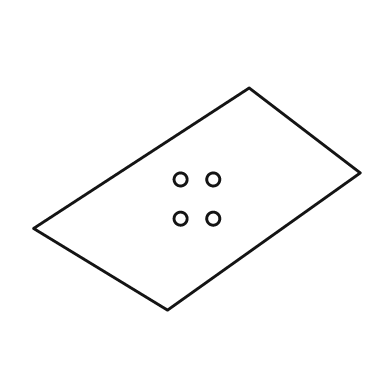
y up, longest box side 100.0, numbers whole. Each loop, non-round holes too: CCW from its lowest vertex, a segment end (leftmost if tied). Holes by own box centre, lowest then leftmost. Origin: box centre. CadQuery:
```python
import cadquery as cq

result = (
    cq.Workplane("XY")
    .moveTo(-9.0, -34.0)
    .lineTo(50.0, 8.0)
    .lineTo(16.0, 34.0)
    .lineTo(-50.0, -9.0)
    .close()
    .moveTo(-5.0, -6.0)
    .circle(2.0)
    .moveTo(5.0, -6.0)
    .circle(2.0)
    .moveTo(-5.0, 6.0)
    .circle(2.0)
    .moveTo(5.0, 6.0)
    .circle(2.0)
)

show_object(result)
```